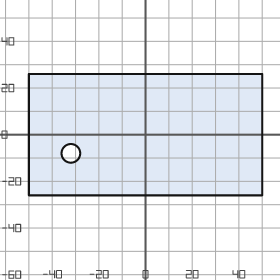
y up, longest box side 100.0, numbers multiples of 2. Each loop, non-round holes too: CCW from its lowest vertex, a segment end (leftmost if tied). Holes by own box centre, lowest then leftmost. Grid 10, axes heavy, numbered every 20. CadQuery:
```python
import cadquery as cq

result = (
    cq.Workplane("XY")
    .moveTo(-50.0, -26.0)
    .lineTo(50.0, -26.0)
    .lineTo(50.0, 26.0)
    .lineTo(-50.0, 26.0)
    .close()
    .moveTo(-32.0, -8.0)
    .circle(4.0)
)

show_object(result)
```